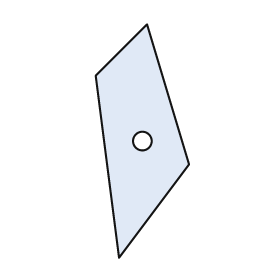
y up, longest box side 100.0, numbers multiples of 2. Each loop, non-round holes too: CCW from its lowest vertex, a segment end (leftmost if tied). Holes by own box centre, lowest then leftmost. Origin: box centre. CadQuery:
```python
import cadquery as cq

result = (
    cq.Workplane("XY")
    .moveTo(-10.0, -50.0)
    .lineTo(20.0, -10.0)
    .lineTo(2.0, 50.0)
    .lineTo(-20.0, 28.0)
    .close()
    .moveTo(0.0, 0.0)
    .circle(4.0)
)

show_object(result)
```